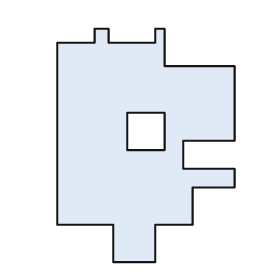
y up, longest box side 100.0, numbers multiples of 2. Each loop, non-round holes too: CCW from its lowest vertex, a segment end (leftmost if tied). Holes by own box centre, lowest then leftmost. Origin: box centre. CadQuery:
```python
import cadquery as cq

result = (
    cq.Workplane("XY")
    .moveTo(-14.0, -50.0)
    .lineTo(4.0, -50.0)
    .lineTo(4.0, -34.0)
    .lineTo(20.0, -34.0)
    .lineTo(20.0, -18.0)
    .lineTo(38.0, -18.0)
    .lineTo(38.0, -10.0)
    .lineTo(16.0, -10.0)
    .lineTo(16.0, 2.0)
    .lineTo(38.0, 2.0)
    .lineTo(38.0, 34.0)
    .lineTo(8.0, 34.0)
    .lineTo(8.0, 50.0)
    .lineTo(4.0, 50.0)
    .lineTo(4.0, 44.0)
    .lineTo(-16.0, 44.0)
    .lineTo(-16.0, 50.0)
    .lineTo(-22.0, 50.0)
    .lineTo(-22.0, 44.0)
    .lineTo(-38.0, 44.0)
    .lineTo(-38.0, -34.0)
    .lineTo(-14.0, -34.0)
    .close()
    .moveTo(-8.0, -2.0)
    .lineTo(8.0, -2.0)
    .lineTo(8.0, 14.0)
    .lineTo(-8.0, 14.0)
    .close()
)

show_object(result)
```